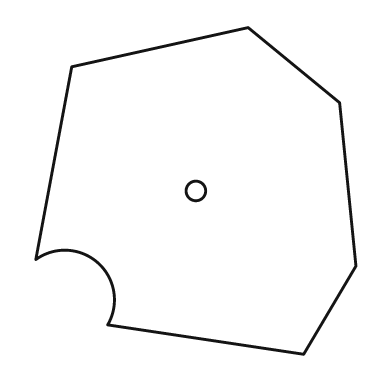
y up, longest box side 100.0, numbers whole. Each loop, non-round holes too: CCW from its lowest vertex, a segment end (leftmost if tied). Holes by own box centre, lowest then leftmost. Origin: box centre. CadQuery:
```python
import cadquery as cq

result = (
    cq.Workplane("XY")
    .moveTo(33.0, -50.0)
    .lineTo(49.0, -23.0)
    .lineTo(44.0, 27.0)
    .lineTo(16.0, 50.0)
    .lineTo(-38.0, 38.0)
    .lineTo(-49.0, -21.0)
    .threePointArc((-30.0, -22.0), (-27.0, -41.0))
    .close()
    .moveTo(0.0, 0.0)
    .circle(3.0)
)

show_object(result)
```